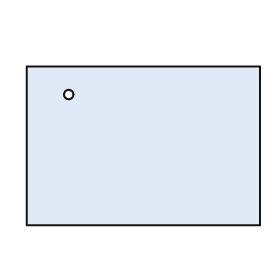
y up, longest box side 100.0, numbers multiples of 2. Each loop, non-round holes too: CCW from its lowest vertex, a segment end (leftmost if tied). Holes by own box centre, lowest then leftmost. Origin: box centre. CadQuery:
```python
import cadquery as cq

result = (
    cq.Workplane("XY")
    .moveTo(-50.0, -34.0)
    .lineTo(50.0, -34.0)
    .lineTo(50.0, 34.0)
    .lineTo(-50.0, 34.0)
    .close()
    .moveTo(-32.0, 22.0)
    .circle(2.0)
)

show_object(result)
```